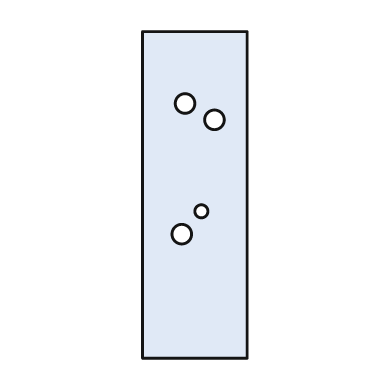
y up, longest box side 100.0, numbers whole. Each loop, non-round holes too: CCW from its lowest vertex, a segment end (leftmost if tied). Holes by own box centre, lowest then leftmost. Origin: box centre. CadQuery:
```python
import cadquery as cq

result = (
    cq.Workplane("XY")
    .moveTo(-16.0, -50.0)
    .lineTo(16.0, -50.0)
    .lineTo(16.0, 50.0)
    .lineTo(-16.0, 50.0)
    .close()
    .moveTo(-4.0, -12.0)
    .circle(3.0)
    .moveTo(2.0, -5.0)
    .circle(2.0)
    .moveTo(6.0, 23.0)
    .circle(3.0)
    .moveTo(-3.0, 28.0)
    .circle(3.0)
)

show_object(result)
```